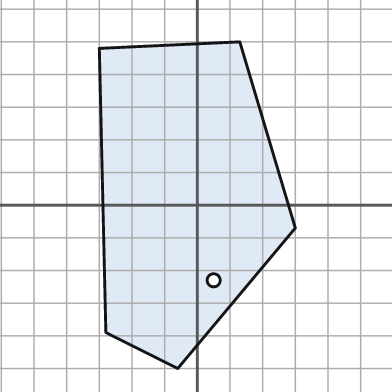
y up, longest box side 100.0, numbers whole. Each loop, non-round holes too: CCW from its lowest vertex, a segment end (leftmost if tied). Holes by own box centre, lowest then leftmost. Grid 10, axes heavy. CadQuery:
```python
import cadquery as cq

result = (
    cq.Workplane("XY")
    .moveTo(-6.0, -50.0)
    .lineTo(30.0, -7.0)
    .lineTo(13.0, 50.0)
    .lineTo(-30.0, 48.0)
    .lineTo(-28.0, -39.0)
    .close()
    .moveTo(5.0, -23.0)
    .circle(2.0)
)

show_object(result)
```